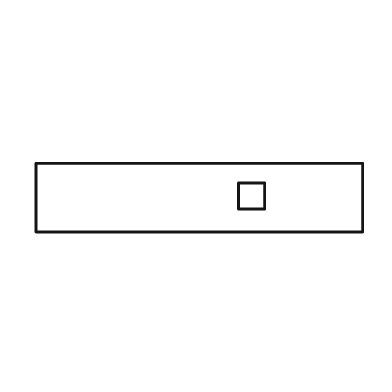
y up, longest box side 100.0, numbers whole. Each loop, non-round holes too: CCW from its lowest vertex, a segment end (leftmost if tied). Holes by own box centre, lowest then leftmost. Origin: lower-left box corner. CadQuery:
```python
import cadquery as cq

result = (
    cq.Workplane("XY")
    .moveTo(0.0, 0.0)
    .lineTo(100.0, 0.0)
    .lineTo(100.0, 21.0)
    .lineTo(0.0, 21.0)
    .close()
    .moveTo(62.0, 7.0)
    .lineTo(70.0, 7.0)
    .lineTo(70.0, 15.0)
    .lineTo(62.0, 15.0)
    .close()
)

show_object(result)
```